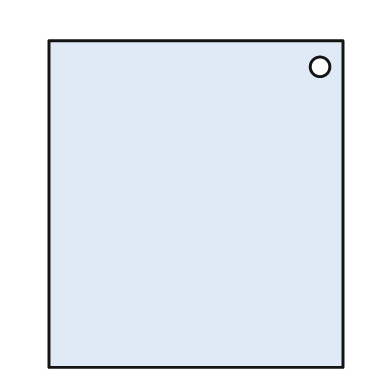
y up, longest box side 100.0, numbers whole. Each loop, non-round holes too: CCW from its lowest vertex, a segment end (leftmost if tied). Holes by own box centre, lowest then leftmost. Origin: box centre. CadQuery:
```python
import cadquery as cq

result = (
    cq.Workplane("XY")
    .moveTo(-45.0, -50.0)
    .lineTo(45.0, -50.0)
    .lineTo(45.0, 50.0)
    .lineTo(-45.0, 50.0)
    .close()
    .moveTo(38.0, 42.0)
    .circle(3.0)
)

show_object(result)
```